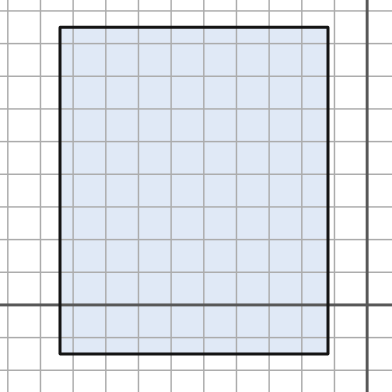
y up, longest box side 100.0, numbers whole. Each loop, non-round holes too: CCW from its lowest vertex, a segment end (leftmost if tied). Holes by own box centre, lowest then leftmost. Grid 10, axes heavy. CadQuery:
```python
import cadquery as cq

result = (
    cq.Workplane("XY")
    .moveTo(-94.0, -15.0)
    .lineTo(-12.0, -15.0)
    .lineTo(-12.0, 85.0)
    .lineTo(-94.0, 85.0)
    .close()
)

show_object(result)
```